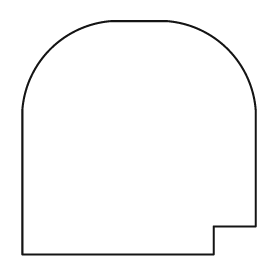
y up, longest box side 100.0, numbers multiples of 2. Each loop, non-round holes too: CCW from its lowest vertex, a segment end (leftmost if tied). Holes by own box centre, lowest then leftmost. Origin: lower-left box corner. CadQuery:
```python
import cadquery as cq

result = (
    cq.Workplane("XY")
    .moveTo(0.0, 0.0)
    .lineTo(82.0, 0.0)
    .lineTo(82.0, 12.0)
    .lineTo(100.0, 12.0)
    .lineTo(100.0, 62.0)
    .threePointArc((88.0, 88.0), (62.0, 100.0))
    .lineTo(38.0, 100.0)
    .threePointArc((12.0, 88.0), (0.0, 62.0))
    .close()
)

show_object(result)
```